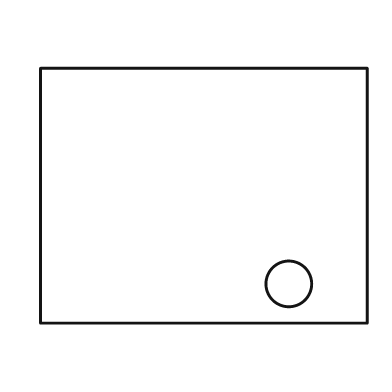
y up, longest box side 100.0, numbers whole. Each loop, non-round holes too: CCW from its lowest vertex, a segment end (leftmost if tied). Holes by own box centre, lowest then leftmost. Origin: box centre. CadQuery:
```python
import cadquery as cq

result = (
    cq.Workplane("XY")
    .moveTo(-50.0, -39.0)
    .lineTo(50.0, -39.0)
    .lineTo(50.0, 39.0)
    .lineTo(-50.0, 39.0)
    .close()
    .moveTo(26.0, -27.0)
    .circle(7.0)
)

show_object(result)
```